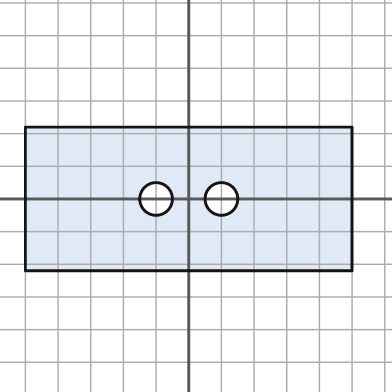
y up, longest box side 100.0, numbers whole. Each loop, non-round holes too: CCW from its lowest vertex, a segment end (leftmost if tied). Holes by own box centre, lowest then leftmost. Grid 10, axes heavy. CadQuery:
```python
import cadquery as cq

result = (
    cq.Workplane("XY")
    .moveTo(-50.0, -22.0)
    .lineTo(50.0, -22.0)
    .lineTo(50.0, 22.0)
    .lineTo(-50.0, 22.0)
    .close()
    .moveTo(-10.0, 0.0)
    .circle(5.0)
    .moveTo(10.0, 0.0)
    .circle(5.0)
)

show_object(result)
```